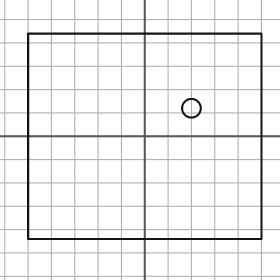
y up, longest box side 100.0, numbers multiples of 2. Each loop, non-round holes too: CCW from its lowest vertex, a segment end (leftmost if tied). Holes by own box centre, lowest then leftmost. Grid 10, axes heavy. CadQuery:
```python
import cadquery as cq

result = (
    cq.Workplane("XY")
    .moveTo(-50.0, -44.0)
    .lineTo(50.0, -44.0)
    .lineTo(50.0, 44.0)
    .lineTo(-50.0, 44.0)
    .close()
    .moveTo(20.0, 12.0)
    .circle(4.0)
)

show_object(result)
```